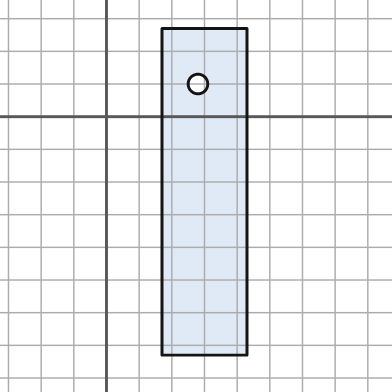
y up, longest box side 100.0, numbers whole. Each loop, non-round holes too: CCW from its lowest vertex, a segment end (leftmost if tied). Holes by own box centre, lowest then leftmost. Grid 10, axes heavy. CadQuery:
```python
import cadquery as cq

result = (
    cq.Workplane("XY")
    .moveTo(17.0, -73.0)
    .lineTo(43.0, -73.0)
    .lineTo(43.0, 27.0)
    .lineTo(17.0, 27.0)
    .close()
    .moveTo(28.0, 10.0)
    .circle(3.0)
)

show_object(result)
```